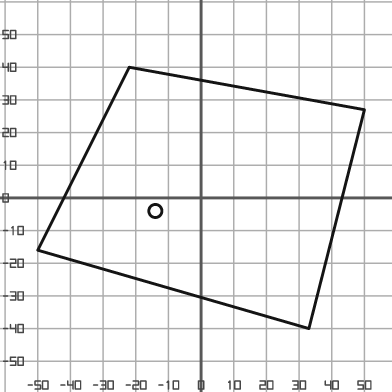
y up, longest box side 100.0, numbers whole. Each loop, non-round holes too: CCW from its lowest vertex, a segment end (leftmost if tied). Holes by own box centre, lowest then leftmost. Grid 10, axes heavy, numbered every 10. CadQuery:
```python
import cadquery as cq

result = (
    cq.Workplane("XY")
    .moveTo(33.0, -40.0)
    .lineTo(50.0, 27.0)
    .lineTo(-22.0, 40.0)
    .lineTo(-50.0, -16.0)
    .close()
    .moveTo(-14.0, -4.0)
    .circle(2.0)
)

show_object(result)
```